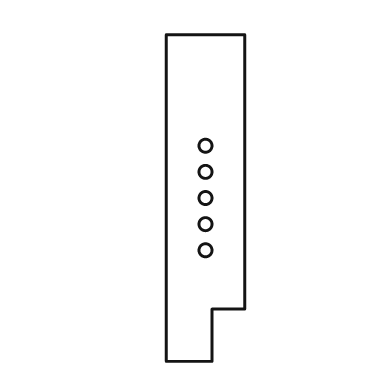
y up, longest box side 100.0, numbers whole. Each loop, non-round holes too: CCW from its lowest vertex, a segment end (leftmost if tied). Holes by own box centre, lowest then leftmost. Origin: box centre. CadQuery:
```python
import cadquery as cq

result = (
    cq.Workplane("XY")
    .moveTo(-12.0, -50.0)
    .lineTo(2.0, -50.0)
    .lineTo(2.0, -34.0)
    .lineTo(12.0, -34.0)
    .lineTo(12.0, 50.0)
    .lineTo(-12.0, 50.0)
    .close()
    .moveTo(0.0, -16.0)
    .circle(2.0)
    .moveTo(0.0, -8.0)
    .circle(2.0)
    .moveTo(0.0, 0.0)
    .circle(2.0)
    .moveTo(0.0, 8.0)
    .circle(2.0)
    .moveTo(0.0, 16.0)
    .circle(2.0)
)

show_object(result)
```